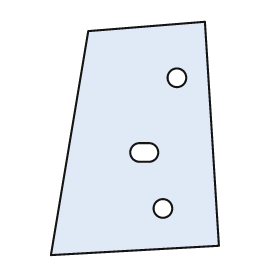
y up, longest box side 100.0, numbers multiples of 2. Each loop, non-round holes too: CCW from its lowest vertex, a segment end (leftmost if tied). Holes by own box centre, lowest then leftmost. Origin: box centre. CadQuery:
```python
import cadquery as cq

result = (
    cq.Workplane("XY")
    .moveTo(-36.0, -50.0)
    .lineTo(36.0, -46.0)
    .lineTo(30.0, 50.0)
    .lineTo(-20.0, 46.0)
    .close()
    .moveTo(12.0, -30.0)
    .circle(4.0)
    .moveTo(2.0, -10.0)
    .lineTo(6.0, -10.0)
    .threePointArc((10.0, -6.0), (6.0, -2.0))
    .lineTo(2.0, -2.0)
    .threePointArc((-2.0, -6.0), (2.0, -10.0))
    .close()
    .moveTo(18.0, 26.0)
    .circle(4.0)
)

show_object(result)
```